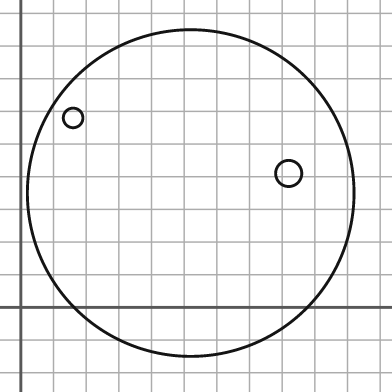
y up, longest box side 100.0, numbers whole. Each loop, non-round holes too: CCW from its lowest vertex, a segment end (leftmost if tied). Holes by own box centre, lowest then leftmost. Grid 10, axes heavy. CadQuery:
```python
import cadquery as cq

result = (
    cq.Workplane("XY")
    .moveTo(52.0, 35.0)
    .circle(50.0)
    .moveTo(82.0, 41.0)
    .circle(4.0)
    .moveTo(16.0, 58.0)
    .circle(3.0)
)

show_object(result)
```